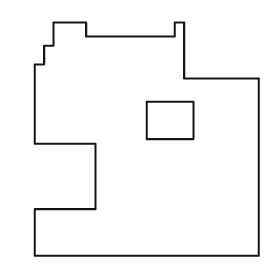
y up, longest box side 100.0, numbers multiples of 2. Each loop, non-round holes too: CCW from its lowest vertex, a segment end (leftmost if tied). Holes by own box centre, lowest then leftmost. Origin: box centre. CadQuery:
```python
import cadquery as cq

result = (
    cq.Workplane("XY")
    .moveTo(-48.0, -50.0)
    .lineTo(48.0, -50.0)
    .lineTo(48.0, 26.0)
    .lineTo(16.0, 26.0)
    .lineTo(16.0, 50.0)
    .lineTo(12.0, 50.0)
    .lineTo(12.0, 44.0)
    .lineTo(-26.0, 44.0)
    .lineTo(-26.0, 50.0)
    .lineTo(-40.0, 50.0)
    .lineTo(-40.0, 40.0)
    .lineTo(-44.0, 40.0)
    .lineTo(-44.0, 32.0)
    .lineTo(-48.0, 32.0)
    .lineTo(-48.0, -2.0)
    .lineTo(-22.0, -2.0)
    .lineTo(-22.0, -30.0)
    .lineTo(-48.0, -30.0)
    .close()
    .moveTo(0.0, 0.0)
    .lineTo(20.0, 0.0)
    .lineTo(20.0, 16.0)
    .lineTo(0.0, 16.0)
    .close()
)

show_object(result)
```